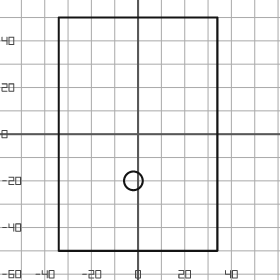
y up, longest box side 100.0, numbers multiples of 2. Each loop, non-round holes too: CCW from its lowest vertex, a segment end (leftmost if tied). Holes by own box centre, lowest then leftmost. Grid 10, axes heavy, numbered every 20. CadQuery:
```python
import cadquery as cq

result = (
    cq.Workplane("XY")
    .moveTo(-34.0, -50.0)
    .lineTo(34.0, -50.0)
    .lineTo(34.0, 50.0)
    .lineTo(-34.0, 50.0)
    .close()
    .moveTo(-2.0, -20.0)
    .circle(4.0)
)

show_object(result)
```